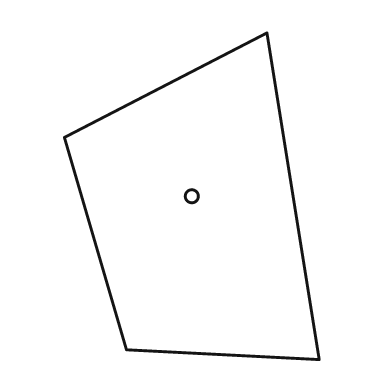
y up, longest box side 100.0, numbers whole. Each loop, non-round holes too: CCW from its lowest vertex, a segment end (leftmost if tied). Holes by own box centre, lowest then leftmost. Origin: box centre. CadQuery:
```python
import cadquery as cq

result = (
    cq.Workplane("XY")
    .moveTo(39.0, -50.0)
    .lineTo(23.0, 50.0)
    .lineTo(-39.0, 18.0)
    .lineTo(-20.0, -47.0)
    .close()
    .moveTo(0.0, 0.0)
    .circle(2.0)
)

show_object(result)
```